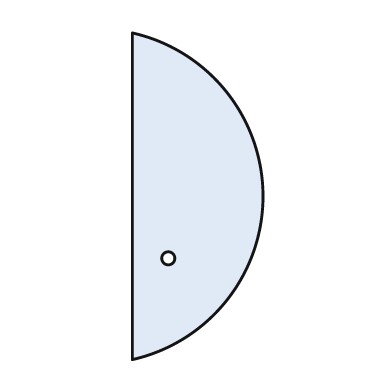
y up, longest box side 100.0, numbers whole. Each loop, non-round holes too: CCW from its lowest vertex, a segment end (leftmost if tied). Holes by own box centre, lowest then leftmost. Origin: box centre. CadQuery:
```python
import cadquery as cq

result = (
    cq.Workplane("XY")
    .moveTo(-20.0, -50.0)
    .threePointArc((20.0, 0.0), (-20.0, 50.0))
    .close()
    .moveTo(-9.0, -19.0)
    .circle(2.0)
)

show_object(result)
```